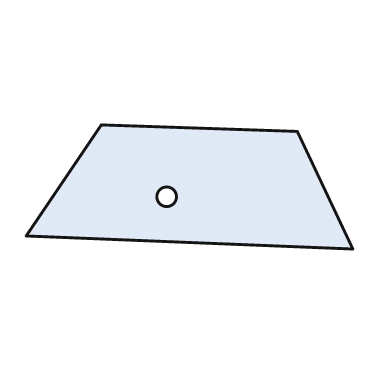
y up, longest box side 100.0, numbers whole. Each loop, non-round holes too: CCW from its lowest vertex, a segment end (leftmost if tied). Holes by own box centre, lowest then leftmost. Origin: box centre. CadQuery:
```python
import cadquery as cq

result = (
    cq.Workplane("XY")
    .moveTo(50.0, -19.0)
    .lineTo(33.0, 17.0)
    .lineTo(-27.0, 19.0)
    .lineTo(-50.0, -15.0)
    .close()
    .moveTo(-7.0, -3.0)
    .circle(3.0)
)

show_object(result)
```